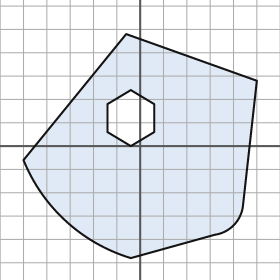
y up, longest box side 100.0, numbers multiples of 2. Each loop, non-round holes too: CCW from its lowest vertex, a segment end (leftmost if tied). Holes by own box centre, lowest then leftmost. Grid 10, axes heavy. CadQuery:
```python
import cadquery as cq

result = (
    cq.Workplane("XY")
    .moveTo(-4.0, -48.0)
    .lineTo(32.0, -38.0)
    .threePointArc((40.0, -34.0), (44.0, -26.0))
    .lineTo(50.0, 28.0)
    .lineTo(-6.0, 48.0)
    .lineTo(-50.0, -6.0)
    .threePointArc((-32.0, -32.0), (-4.0, -48.0))
    .close()
    .moveTo(-4.0, 0.0)
    .lineTo(6.0, 6.0)
    .lineTo(6.0, 18.0)
    .lineTo(-4.0, 24.0)
    .lineTo(-14.0, 18.0)
    .lineTo(-14.0, 6.0)
    .close()
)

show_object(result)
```